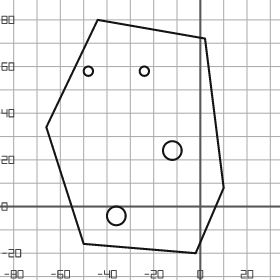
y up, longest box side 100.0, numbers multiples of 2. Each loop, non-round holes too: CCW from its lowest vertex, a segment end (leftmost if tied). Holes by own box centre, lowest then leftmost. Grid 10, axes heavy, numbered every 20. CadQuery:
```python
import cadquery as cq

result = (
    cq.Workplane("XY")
    .moveTo(-2.0, -20.0)
    .lineTo(10.0, 8.0)
    .lineTo(2.0, 72.0)
    .lineTo(-44.0, 80.0)
    .lineTo(-66.0, 34.0)
    .lineTo(-50.0, -16.0)
    .close()
    .moveTo(-36.0, -4.0)
    .circle(4.0)
    .moveTo(-12.0, 24.0)
    .circle(4.0)
    .moveTo(-48.0, 58.0)
    .circle(2.0)
    .moveTo(-24.0, 58.0)
    .circle(2.0)
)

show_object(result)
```